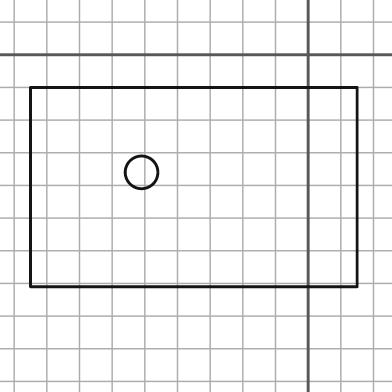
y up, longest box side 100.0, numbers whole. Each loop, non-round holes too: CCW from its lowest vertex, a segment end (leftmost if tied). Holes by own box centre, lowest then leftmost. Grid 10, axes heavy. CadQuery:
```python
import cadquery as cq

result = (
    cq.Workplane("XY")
    .moveTo(-85.0, -71.0)
    .lineTo(15.0, -71.0)
    .lineTo(15.0, -10.0)
    .lineTo(-85.0, -10.0)
    .close()
    .moveTo(-51.0, -36.0)
    .circle(5.0)
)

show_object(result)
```